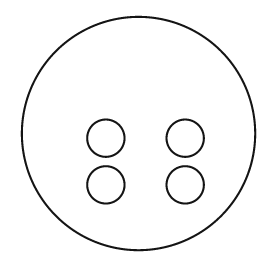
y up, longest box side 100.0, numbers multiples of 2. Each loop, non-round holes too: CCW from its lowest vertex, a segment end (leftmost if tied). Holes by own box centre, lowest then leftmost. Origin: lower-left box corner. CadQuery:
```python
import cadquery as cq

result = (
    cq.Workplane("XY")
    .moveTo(50.0, 50.0)
    .circle(50.0)
    .moveTo(36.0, 28.0)
    .circle(8.0)
    .moveTo(70.0, 28.0)
    .circle(8.0)
    .moveTo(36.0, 48.0)
    .circle(8.0)
    .moveTo(70.0, 48.0)
    .circle(8.0)
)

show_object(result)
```